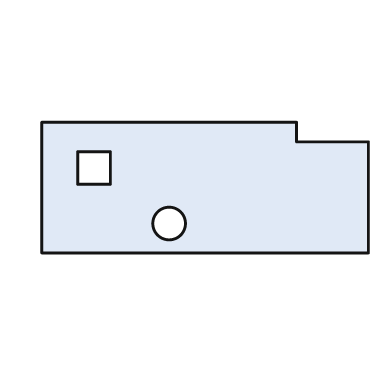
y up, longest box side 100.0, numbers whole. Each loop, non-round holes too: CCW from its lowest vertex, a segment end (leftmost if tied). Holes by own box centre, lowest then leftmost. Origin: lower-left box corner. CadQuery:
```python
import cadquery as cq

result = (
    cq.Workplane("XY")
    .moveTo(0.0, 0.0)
    .lineTo(100.0, 0.0)
    .lineTo(100.0, 34.0)
    .lineTo(78.0, 34.0)
    .lineTo(78.0, 40.0)
    .lineTo(0.0, 40.0)
    .close()
    .moveTo(39.0, 9.0)
    .circle(5.0)
    .moveTo(11.0, 21.0)
    .lineTo(21.0, 21.0)
    .lineTo(21.0, 31.0)
    .lineTo(11.0, 31.0)
    .close()
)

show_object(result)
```